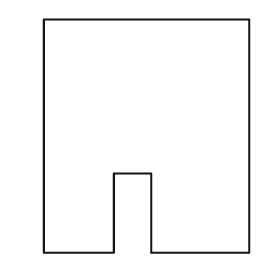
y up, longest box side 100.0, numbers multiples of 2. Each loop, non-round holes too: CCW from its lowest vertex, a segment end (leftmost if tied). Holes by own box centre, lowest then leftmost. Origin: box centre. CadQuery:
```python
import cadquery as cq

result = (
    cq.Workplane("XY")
    .moveTo(-44.0, -50.0)
    .lineTo(-14.0, -50.0)
    .lineTo(-14.0, -16.0)
    .lineTo(2.0, -16.0)
    .lineTo(2.0, -50.0)
    .lineTo(44.0, -50.0)
    .lineTo(44.0, 50.0)
    .lineTo(-44.0, 50.0)
    .close()
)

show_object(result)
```